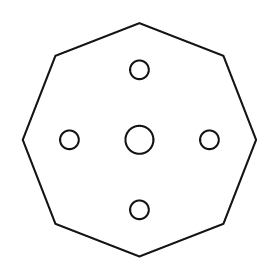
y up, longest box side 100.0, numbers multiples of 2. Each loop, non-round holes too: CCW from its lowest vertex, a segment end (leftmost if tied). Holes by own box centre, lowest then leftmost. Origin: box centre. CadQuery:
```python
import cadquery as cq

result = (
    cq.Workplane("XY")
    .moveTo(0.0, -50.0)
    .lineTo(36.0, -36.0)
    .lineTo(50.0, 0.0)
    .lineTo(36.0, 36.0)
    .lineTo(0.0, 50.0)
    .lineTo(-36.0, 36.0)
    .lineTo(-50.0, 0.0)
    .lineTo(-36.0, -36.0)
    .close()
    .moveTo(0.0, -30.0)
    .circle(4.0)
    .moveTo(-30.0, 0.0)
    .circle(4.0)
    .moveTo(0.0, 0.0)
    .circle(6.0)
    .moveTo(30.0, 0.0)
    .circle(4.0)
    .moveTo(0.0, 30.0)
    .circle(4.0)
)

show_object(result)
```